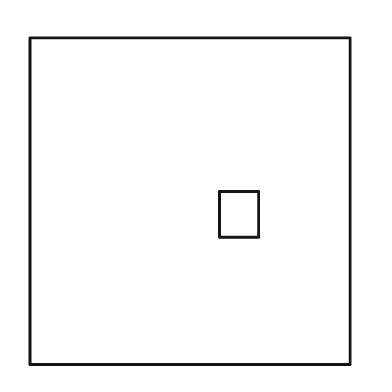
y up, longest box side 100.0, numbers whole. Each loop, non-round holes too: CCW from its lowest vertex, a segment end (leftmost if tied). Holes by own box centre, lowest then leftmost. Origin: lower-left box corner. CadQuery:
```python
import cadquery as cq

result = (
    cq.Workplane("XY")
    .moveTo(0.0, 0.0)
    .lineTo(98.0, 0.0)
    .lineTo(98.0, 100.0)
    .lineTo(0.0, 100.0)
    .close()
    .moveTo(58.0, 39.0)
    .lineTo(70.0, 39.0)
    .lineTo(70.0, 53.0)
    .lineTo(58.0, 53.0)
    .close()
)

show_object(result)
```